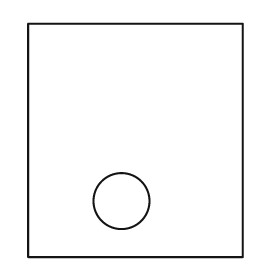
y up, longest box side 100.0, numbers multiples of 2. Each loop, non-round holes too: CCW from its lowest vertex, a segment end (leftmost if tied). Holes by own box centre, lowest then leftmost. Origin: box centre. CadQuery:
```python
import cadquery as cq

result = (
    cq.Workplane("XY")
    .moveTo(-46.0, -50.0)
    .lineTo(46.0, -50.0)
    .lineTo(46.0, 50.0)
    .lineTo(-46.0, 50.0)
    .close()
    .moveTo(-6.0, -26.0)
    .circle(12.0)
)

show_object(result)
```